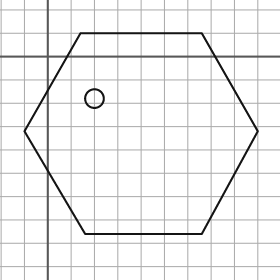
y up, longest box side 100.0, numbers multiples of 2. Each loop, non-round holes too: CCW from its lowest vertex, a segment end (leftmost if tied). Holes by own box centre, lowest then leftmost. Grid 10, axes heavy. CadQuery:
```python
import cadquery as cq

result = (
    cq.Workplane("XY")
    .moveTo(16.0, -76.0)
    .lineTo(66.0, -76.0)
    .lineTo(90.0, -32.0)
    .lineTo(66.0, 10.0)
    .lineTo(14.0, 10.0)
    .lineTo(-10.0, -32.0)
    .close()
    .moveTo(20.0, -18.0)
    .circle(4.0)
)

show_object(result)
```